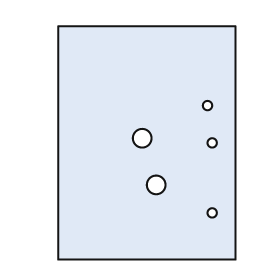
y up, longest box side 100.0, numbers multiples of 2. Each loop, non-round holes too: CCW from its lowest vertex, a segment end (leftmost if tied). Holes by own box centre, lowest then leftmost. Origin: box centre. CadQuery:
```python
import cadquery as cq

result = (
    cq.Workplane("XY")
    .moveTo(-38.0, -50.0)
    .lineTo(38.0, -50.0)
    .lineTo(38.0, 50.0)
    .lineTo(-38.0, 50.0)
    .close()
    .moveTo(28.0, -30.0)
    .circle(2.0)
    .moveTo(4.0, -18.0)
    .circle(4.0)
    .moveTo(28.0, 0.0)
    .circle(2.0)
    .moveTo(-2.0, 2.0)
    .circle(4.0)
    .moveTo(26.0, 16.0)
    .circle(2.0)
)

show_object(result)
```